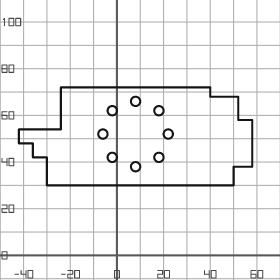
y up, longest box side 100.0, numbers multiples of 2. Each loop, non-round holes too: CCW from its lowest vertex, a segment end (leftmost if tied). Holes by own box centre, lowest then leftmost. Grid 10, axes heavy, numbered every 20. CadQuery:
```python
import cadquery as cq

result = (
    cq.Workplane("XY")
    .moveTo(-30.0, 30.0)
    .lineTo(50.0, 30.0)
    .lineTo(50.0, 38.0)
    .lineTo(58.0, 38.0)
    .lineTo(58.0, 58.0)
    .lineTo(52.0, 58.0)
    .lineTo(52.0, 68.0)
    .lineTo(40.0, 68.0)
    .lineTo(40.0, 72.0)
    .lineTo(-24.0, 72.0)
    .lineTo(-24.0, 54.0)
    .lineTo(-42.0, 54.0)
    .lineTo(-42.0, 48.0)
    .lineTo(-36.0, 48.0)
    .lineTo(-36.0, 42.0)
    .lineTo(-30.0, 42.0)
    .close()
    .moveTo(8.0, 38.0)
    .circle(2.0)
    .moveTo(-2.0, 42.0)
    .circle(2.0)
    .moveTo(18.0, 42.0)
    .circle(2.0)
    .moveTo(-6.0, 52.0)
    .circle(2.0)
    .moveTo(22.0, 52.0)
    .circle(2.0)
    .moveTo(-2.0, 62.0)
    .circle(2.0)
    .moveTo(18.0, 62.0)
    .circle(2.0)
    .moveTo(8.0, 66.0)
    .circle(2.0)
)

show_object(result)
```